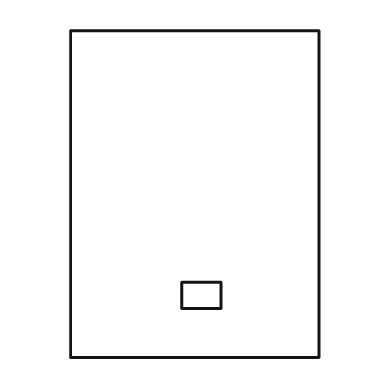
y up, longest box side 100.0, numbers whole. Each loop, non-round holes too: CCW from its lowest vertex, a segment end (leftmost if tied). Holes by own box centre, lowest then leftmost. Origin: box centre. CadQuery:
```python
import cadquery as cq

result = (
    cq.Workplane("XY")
    .moveTo(-38.0, -50.0)
    .lineTo(38.0, -50.0)
    .lineTo(38.0, 50.0)
    .lineTo(-38.0, 50.0)
    .close()
    .moveTo(-4.0, -35.0)
    .lineTo(8.0, -35.0)
    .lineTo(8.0, -27.0)
    .lineTo(-4.0, -27.0)
    .close()
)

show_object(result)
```